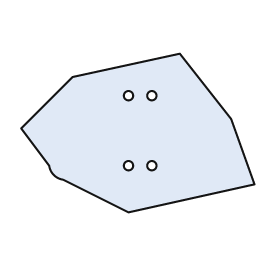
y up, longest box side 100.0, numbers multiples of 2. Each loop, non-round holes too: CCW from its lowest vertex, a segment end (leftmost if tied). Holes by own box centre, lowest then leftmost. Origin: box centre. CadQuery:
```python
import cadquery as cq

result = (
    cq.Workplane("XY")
    .moveTo(-4.0, -34.0)
    .lineTo(50.0, -22.0)
    .lineTo(40.0, 6.0)
    .lineTo(18.0, 34.0)
    .lineTo(-28.0, 24.0)
    .lineTo(-50.0, 2.0)
    .lineTo(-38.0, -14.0)
    .threePointArc((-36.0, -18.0), (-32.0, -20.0))
    .close()
    .moveTo(-4.0, -14.0)
    .circle(2.0)
    .moveTo(6.0, -14.0)
    .circle(2.0)
    .moveTo(-4.0, 16.0)
    .circle(2.0)
    .moveTo(6.0, 16.0)
    .circle(2.0)
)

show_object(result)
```